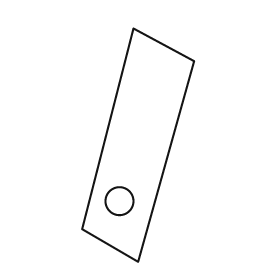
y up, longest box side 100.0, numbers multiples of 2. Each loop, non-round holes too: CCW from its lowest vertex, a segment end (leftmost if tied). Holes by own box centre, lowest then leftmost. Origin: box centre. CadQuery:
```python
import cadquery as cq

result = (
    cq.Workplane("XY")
    .moveTo(0.0, -50.0)
    .lineTo(24.0, 36.0)
    .lineTo(-2.0, 50.0)
    .lineTo(-24.0, -36.0)
    .close()
    .moveTo(-8.0, -24.0)
    .circle(6.0)
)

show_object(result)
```